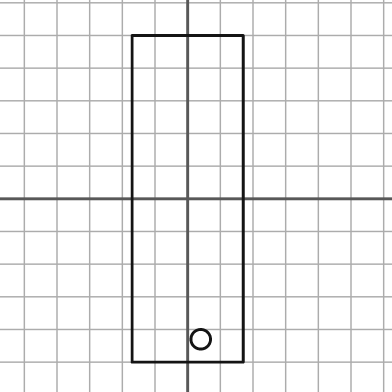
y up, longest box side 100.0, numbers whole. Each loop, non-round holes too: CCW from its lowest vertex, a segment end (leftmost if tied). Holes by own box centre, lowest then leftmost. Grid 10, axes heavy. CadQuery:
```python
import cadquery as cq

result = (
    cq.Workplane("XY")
    .moveTo(-17.0, -50.0)
    .lineTo(17.0, -50.0)
    .lineTo(17.0, 50.0)
    .lineTo(-17.0, 50.0)
    .close()
    .moveTo(4.0, -43.0)
    .circle(3.0)
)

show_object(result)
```